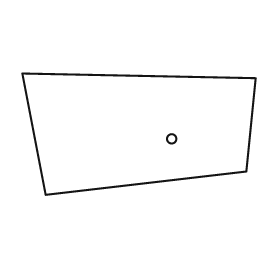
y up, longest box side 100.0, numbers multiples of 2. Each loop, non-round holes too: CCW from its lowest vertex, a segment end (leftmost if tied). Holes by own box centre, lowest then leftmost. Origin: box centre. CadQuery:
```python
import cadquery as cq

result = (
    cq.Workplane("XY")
    .moveTo(-40.0, -26.0)
    .lineTo(46.0, -16.0)
    .lineTo(50.0, 24.0)
    .lineTo(-50.0, 26.0)
    .close()
    .moveTo(14.0, -2.0)
    .circle(2.0)
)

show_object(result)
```